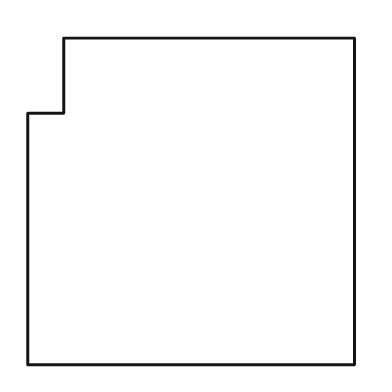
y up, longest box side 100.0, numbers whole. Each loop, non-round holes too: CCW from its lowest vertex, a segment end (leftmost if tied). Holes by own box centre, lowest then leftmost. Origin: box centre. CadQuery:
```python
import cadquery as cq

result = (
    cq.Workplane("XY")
    .moveTo(-50.0, -50.0)
    .lineTo(50.0, -50.0)
    .lineTo(50.0, 50.0)
    .lineTo(-39.0, 50.0)
    .lineTo(-39.0, 27.0)
    .lineTo(-50.0, 27.0)
    .close()
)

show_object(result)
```